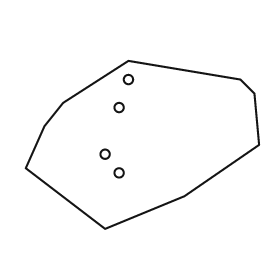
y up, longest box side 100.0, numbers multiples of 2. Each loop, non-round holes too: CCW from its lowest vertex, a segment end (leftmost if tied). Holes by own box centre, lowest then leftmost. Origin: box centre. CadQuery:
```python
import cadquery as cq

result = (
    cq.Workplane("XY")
    .moveTo(-16.0, -36.0)
    .lineTo(18.0, -22.0)
    .lineTo(50.0, 0.0)
    .lineTo(48.0, 22.0)
    .lineTo(42.0, 28.0)
    .lineTo(-6.0, 36.0)
    .lineTo(-34.0, 18.0)
    .lineTo(-42.0, 8.0)
    .lineTo(-50.0, -10.0)
    .close()
    .moveTo(-10.0, -12.0)
    .circle(2.0)
    .moveTo(-16.0, -4.0)
    .circle(2.0)
    .moveTo(-10.0, 16.0)
    .circle(2.0)
    .moveTo(-6.0, 28.0)
    .circle(2.0)
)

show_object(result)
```